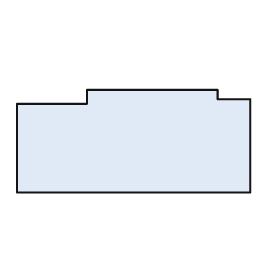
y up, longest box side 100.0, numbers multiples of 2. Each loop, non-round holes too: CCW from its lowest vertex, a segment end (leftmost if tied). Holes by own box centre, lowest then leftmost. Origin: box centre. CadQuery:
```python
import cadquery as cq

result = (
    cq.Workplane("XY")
    .moveTo(-50.0, -22.0)
    .lineTo(50.0, -22.0)
    .lineTo(50.0, 18.0)
    .lineTo(36.0, 18.0)
    .lineTo(36.0, 22.0)
    .lineTo(-20.0, 22.0)
    .lineTo(-20.0, 16.0)
    .lineTo(-50.0, 16.0)
    .close()
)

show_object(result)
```